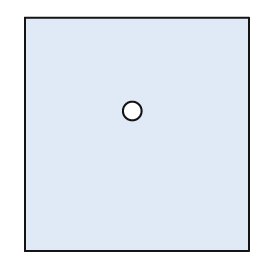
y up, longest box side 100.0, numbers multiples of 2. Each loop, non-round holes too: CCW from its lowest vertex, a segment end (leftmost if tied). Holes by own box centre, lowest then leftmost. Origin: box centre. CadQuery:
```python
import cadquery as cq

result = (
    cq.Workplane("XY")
    .moveTo(-48.0, -50.0)
    .lineTo(48.0, -50.0)
    .lineTo(48.0, 50.0)
    .lineTo(-48.0, 50.0)
    .close()
    .moveTo(-2.0, 10.0)
    .circle(4.0)
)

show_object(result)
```